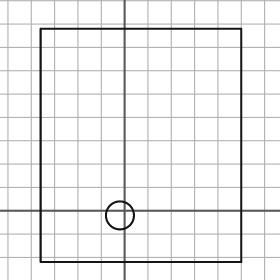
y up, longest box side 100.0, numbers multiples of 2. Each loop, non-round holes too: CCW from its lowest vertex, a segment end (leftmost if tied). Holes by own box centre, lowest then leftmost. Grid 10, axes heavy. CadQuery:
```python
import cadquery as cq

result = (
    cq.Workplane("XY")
    .moveTo(-36.0, -22.0)
    .lineTo(50.0, -22.0)
    .lineTo(50.0, 78.0)
    .lineTo(-36.0, 78.0)
    .close()
    .moveTo(-2.0, -2.0)
    .circle(6.0)
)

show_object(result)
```